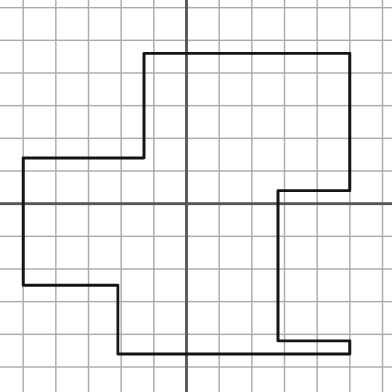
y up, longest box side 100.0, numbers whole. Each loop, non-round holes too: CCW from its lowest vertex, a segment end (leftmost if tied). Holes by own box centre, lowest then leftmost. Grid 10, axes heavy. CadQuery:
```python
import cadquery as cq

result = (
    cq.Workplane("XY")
    .moveTo(-21.0, -46.0)
    .lineTo(50.0, -46.0)
    .lineTo(50.0, -42.0)
    .lineTo(28.0, -42.0)
    .lineTo(28.0, 4.0)
    .lineTo(50.0, 4.0)
    .lineTo(50.0, 46.0)
    .lineTo(-13.0, 46.0)
    .lineTo(-13.0, 14.0)
    .lineTo(-50.0, 14.0)
    .lineTo(-50.0, -25.0)
    .lineTo(-21.0, -25.0)
    .close()
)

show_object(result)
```